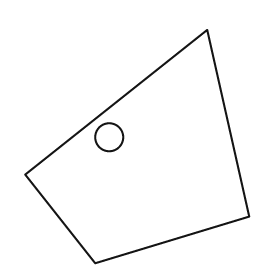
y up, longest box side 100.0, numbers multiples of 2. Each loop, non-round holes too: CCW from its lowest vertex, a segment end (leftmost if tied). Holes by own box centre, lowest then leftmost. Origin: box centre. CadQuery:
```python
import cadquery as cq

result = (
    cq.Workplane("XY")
    .moveTo(-18.0, -50.0)
    .lineTo(48.0, -30.0)
    .lineTo(30.0, 50.0)
    .lineTo(-48.0, -12.0)
    .close()
    .moveTo(-12.0, 4.0)
    .circle(6.0)
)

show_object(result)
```